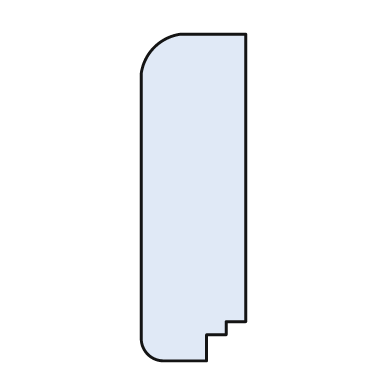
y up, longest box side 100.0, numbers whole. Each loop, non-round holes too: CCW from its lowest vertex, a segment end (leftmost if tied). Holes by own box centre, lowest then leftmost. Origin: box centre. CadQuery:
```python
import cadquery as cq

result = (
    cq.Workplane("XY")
    .moveTo(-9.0, -50.0)
    .lineTo(4.0, -50.0)
    .lineTo(4.0, -42.0)
    .lineTo(10.0, -42.0)
    .lineTo(10.0, -38.0)
    .lineTo(16.0, -38.0)
    .lineTo(16.0, 50.0)
    .lineTo(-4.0, 50.0)
    .threePointArc((-12.0, 46.0), (-16.0, 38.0))
    .lineTo(-16.0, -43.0)
    .threePointArc((-14.0, -48.0), (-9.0, -50.0))
    .close()
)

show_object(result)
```